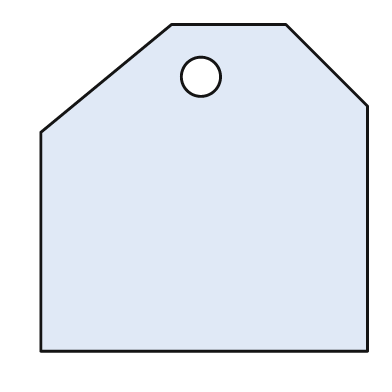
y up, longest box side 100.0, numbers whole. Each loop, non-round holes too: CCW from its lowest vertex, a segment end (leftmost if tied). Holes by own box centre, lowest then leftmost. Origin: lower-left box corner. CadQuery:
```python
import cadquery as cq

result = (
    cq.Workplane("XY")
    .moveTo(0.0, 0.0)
    .lineTo(100.0, 0.0)
    .lineTo(100.0, 75.0)
    .lineTo(75.0, 100.0)
    .lineTo(40.0, 100.0)
    .lineTo(0.0, 67.0)
    .close()
    .moveTo(49.0, 84.0)
    .circle(6.0)
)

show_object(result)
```